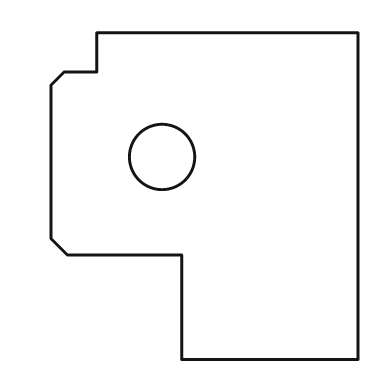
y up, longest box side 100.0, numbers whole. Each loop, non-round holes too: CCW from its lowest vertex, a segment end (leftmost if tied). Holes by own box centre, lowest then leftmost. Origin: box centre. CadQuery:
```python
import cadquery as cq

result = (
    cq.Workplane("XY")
    .moveTo(-7.0, -50.0)
    .lineTo(47.0, -50.0)
    .lineTo(47.0, 50.0)
    .lineTo(-33.0, 50.0)
    .lineTo(-33.0, 38.0)
    .lineTo(-43.0, 38.0)
    .lineTo(-47.0, 34.0)
    .lineTo(-47.0, -13.0)
    .lineTo(-42.0, -18.0)
    .lineTo(-7.0, -18.0)
    .close()
    .moveTo(-13.0, 12.0)
    .circle(10.0)
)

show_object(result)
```